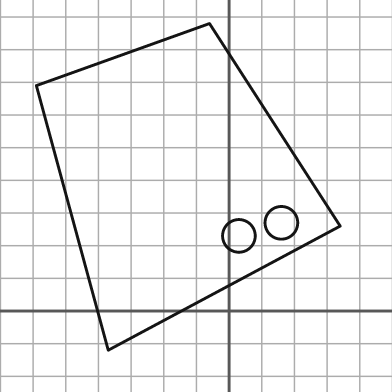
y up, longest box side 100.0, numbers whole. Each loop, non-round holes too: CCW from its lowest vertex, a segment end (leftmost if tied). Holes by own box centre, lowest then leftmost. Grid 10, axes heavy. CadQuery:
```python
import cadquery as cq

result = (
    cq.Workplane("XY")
    .moveTo(-37.0, -12.0)
    .lineTo(34.0, 26.0)
    .lineTo(-6.0, 88.0)
    .lineTo(-59.0, 69.0)
    .close()
    .moveTo(3.0, 23.0)
    .circle(5.0)
    .moveTo(16.0, 27.0)
    .circle(5.0)
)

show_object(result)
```